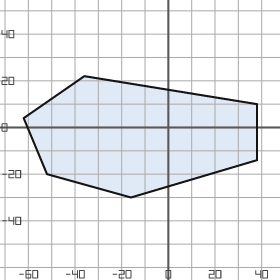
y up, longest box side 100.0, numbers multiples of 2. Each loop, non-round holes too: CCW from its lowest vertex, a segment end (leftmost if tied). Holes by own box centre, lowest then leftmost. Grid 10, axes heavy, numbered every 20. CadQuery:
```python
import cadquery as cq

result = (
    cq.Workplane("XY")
    .moveTo(-16.0, -30.0)
    .lineTo(38.0, -14.0)
    .lineTo(38.0, 10.0)
    .lineTo(-36.0, 22.0)
    .lineTo(-62.0, 4.0)
    .lineTo(-52.0, -20.0)
    .close()
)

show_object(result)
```